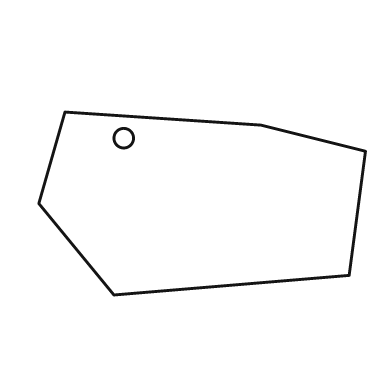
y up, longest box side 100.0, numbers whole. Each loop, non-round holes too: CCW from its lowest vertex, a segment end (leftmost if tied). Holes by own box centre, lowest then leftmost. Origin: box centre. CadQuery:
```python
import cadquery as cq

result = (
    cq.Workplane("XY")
    .moveTo(-27.0, -28.0)
    .lineTo(45.0, -22.0)
    .lineTo(50.0, 16.0)
    .lineTo(18.0, 24.0)
    .lineTo(-42.0, 28.0)
    .lineTo(-50.0, 0.0)
    .close()
    .moveTo(-24.0, 20.0)
    .circle(3.0)
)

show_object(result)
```